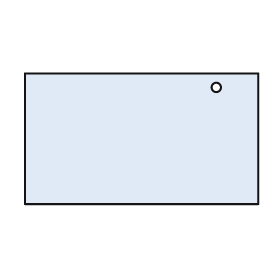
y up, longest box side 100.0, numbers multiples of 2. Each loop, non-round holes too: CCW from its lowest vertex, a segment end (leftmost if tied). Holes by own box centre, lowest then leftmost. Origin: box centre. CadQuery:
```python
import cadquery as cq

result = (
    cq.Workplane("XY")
    .moveTo(-50.0, -28.0)
    .lineTo(50.0, -28.0)
    .lineTo(50.0, 28.0)
    .lineTo(-50.0, 28.0)
    .close()
    .moveTo(32.0, 22.0)
    .circle(2.0)
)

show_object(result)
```